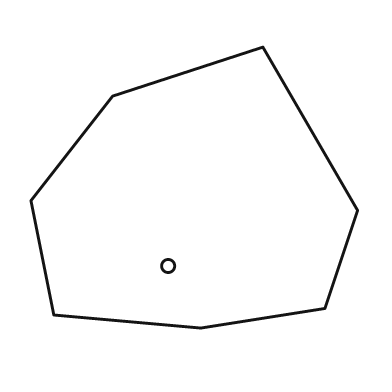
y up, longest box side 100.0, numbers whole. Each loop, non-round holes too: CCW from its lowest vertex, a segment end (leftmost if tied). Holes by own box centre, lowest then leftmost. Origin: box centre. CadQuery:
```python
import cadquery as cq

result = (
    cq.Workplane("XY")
    .moveTo(2.0, -43.0)
    .lineTo(40.0, -37.0)
    .lineTo(50.0, -7.0)
    .lineTo(21.0, 43.0)
    .lineTo(-25.0, 28.0)
    .lineTo(-50.0, -4.0)
    .lineTo(-43.0, -39.0)
    .close()
    .moveTo(-8.0, -24.0)
    .circle(2.0)
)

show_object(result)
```